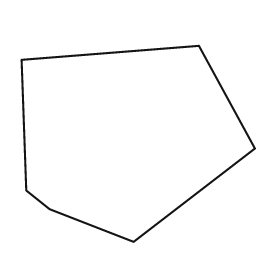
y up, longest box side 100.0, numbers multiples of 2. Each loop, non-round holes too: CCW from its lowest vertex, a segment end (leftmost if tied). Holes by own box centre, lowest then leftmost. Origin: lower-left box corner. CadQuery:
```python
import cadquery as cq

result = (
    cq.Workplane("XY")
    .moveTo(48.0, 0.0)
    .lineTo(100.0, 40.0)
    .lineTo(76.0, 84.0)
    .lineTo(0.0, 78.0)
    .lineTo(2.0, 22.0)
    .lineTo(12.0, 14.0)
    .close()
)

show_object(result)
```